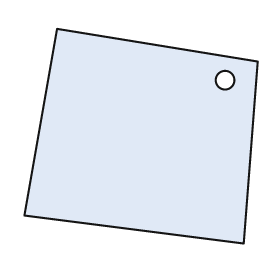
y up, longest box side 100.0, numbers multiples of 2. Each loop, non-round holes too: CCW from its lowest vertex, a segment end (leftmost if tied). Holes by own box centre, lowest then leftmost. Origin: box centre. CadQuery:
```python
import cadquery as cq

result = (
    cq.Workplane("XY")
    .moveTo(44.0, -46.0)
    .lineTo(50.0, 32.0)
    .lineTo(-36.0, 46.0)
    .lineTo(-50.0, -34.0)
    .close()
    .moveTo(36.0, 24.0)
    .circle(4.0)
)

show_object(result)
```